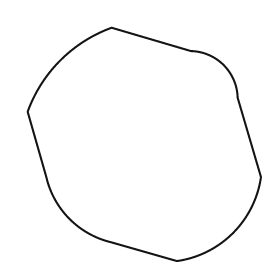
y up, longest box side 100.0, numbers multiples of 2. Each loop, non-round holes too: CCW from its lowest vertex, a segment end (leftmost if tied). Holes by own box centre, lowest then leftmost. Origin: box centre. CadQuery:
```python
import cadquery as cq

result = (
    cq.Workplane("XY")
    .moveTo(14.0, -50.0)
    .threePointArc((38.0, -38.0), (50.0, -14.0))
    .lineTo(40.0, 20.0)
    .threePointArc((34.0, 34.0), (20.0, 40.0))
    .lineTo(-14.0, 50.0)
    .threePointArc((-36.0, 36.0), (-50.0, 14.0))
    .lineTo(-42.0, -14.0)
    .threePointArc((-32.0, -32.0), (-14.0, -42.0))
    .close()
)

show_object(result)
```